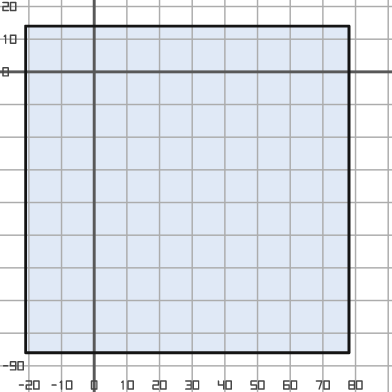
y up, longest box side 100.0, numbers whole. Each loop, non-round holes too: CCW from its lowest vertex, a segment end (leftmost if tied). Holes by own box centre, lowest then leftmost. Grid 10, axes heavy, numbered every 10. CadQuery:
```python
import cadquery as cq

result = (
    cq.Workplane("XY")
    .moveTo(-21.0, -86.0)
    .lineTo(78.0, -86.0)
    .lineTo(78.0, 14.0)
    .lineTo(-21.0, 14.0)
    .close()
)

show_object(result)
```